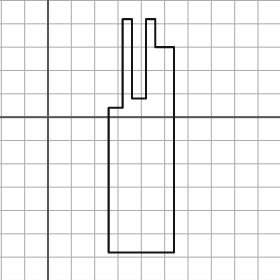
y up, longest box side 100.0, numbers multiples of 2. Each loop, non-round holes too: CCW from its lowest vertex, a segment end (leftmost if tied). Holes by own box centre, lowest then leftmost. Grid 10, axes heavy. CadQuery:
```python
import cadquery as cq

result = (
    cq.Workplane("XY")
    .moveTo(26.0, -58.0)
    .lineTo(54.0, -58.0)
    .lineTo(54.0, 30.0)
    .lineTo(46.0, 30.0)
    .lineTo(46.0, 42.0)
    .lineTo(42.0, 42.0)
    .lineTo(42.0, 8.0)
    .lineTo(36.0, 8.0)
    .lineTo(36.0, 42.0)
    .lineTo(32.0, 42.0)
    .lineTo(32.0, 4.0)
    .lineTo(26.0, 4.0)
    .close()
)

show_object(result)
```